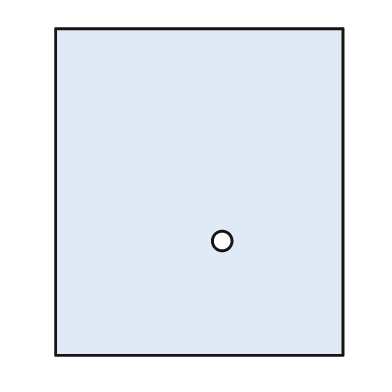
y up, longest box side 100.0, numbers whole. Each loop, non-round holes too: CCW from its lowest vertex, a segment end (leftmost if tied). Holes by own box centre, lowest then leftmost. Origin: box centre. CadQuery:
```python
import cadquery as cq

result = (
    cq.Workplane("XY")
    .moveTo(-44.0, -50.0)
    .lineTo(44.0, -50.0)
    .lineTo(44.0, 50.0)
    .lineTo(-44.0, 50.0)
    .close()
    .moveTo(7.0, -15.0)
    .circle(3.0)
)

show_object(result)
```